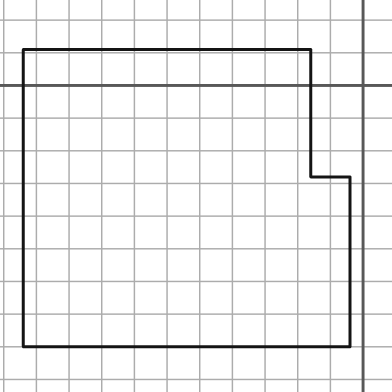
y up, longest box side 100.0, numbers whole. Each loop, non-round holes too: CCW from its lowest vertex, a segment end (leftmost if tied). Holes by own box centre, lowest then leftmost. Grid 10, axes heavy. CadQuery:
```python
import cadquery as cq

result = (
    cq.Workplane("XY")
    .moveTo(-104.0, -80.0)
    .lineTo(-4.0, -80.0)
    .lineTo(-4.0, -28.0)
    .lineTo(-16.0, -28.0)
    .lineTo(-16.0, 11.0)
    .lineTo(-104.0, 11.0)
    .close()
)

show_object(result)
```